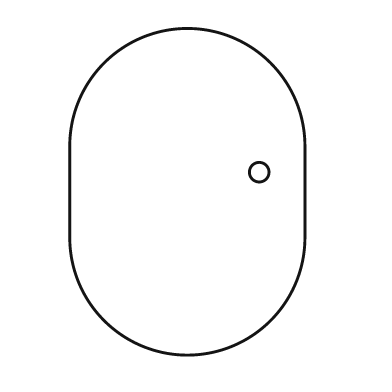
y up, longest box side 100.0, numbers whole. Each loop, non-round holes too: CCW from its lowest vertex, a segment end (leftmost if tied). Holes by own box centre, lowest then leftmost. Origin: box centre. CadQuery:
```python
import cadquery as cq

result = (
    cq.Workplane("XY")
    .moveTo(-36.0, -14.0)
    .threePointArc((0.0, -50.0), (36.0, -14.0))
    .lineTo(36.0, 14.0)
    .threePointArc((0.0, 50.0), (-36.0, 14.0))
    .close()
    .moveTo(22.0, 6.0)
    .circle(3.0)
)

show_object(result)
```